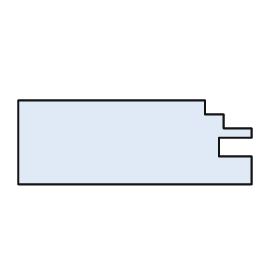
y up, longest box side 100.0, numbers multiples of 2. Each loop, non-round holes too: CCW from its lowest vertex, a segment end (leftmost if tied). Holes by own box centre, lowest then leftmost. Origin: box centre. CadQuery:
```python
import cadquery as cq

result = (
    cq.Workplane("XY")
    .moveTo(-50.0, -18.0)
    .lineTo(50.0, -18.0)
    .lineTo(50.0, -6.0)
    .lineTo(36.0, -6.0)
    .lineTo(36.0, 2.0)
    .lineTo(50.0, 2.0)
    .lineTo(50.0, 6.0)
    .lineTo(38.0, 6.0)
    .lineTo(38.0, 12.0)
    .lineTo(30.0, 12.0)
    .lineTo(30.0, 18.0)
    .lineTo(-50.0, 18.0)
    .close()
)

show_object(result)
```